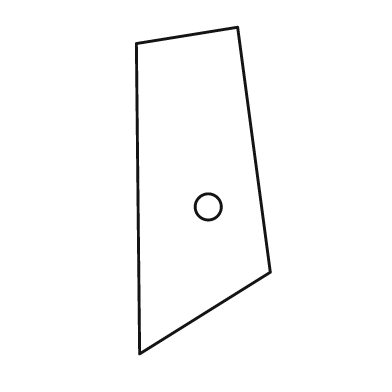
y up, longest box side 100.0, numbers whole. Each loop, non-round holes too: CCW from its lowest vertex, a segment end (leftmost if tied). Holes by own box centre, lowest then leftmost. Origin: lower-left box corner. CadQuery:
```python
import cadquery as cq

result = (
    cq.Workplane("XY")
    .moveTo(1.0, 0.0)
    .lineTo(41.0, 25.0)
    .lineTo(31.0, 100.0)
    .lineTo(0.0, 95.0)
    .close()
    .moveTo(22.0, 45.0)
    .circle(4.0)
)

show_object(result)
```